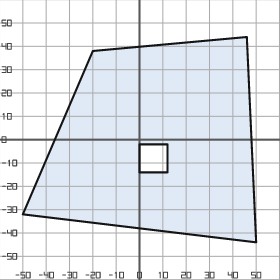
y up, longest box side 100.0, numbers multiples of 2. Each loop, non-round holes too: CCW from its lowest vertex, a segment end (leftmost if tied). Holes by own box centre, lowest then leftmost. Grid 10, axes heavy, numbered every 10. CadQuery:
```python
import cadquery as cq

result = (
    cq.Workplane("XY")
    .moveTo(50.0, -44.0)
    .lineTo(46.0, 44.0)
    .lineTo(-20.0, 38.0)
    .lineTo(-50.0, -32.0)
    .close()
    .moveTo(0.0, -14.0)
    .lineTo(12.0, -14.0)
    .lineTo(12.0, -2.0)
    .lineTo(0.0, -2.0)
    .close()
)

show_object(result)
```